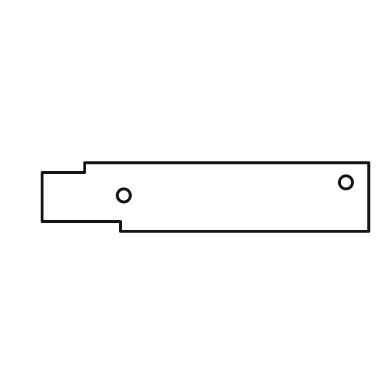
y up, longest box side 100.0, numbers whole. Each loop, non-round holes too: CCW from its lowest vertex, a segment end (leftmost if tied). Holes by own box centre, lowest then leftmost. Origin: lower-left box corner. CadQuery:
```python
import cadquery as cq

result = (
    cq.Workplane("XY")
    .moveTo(24.0, 0.0)
    .lineTo(100.0, 0.0)
    .lineTo(100.0, 21.0)
    .lineTo(13.0, 21.0)
    .lineTo(13.0, 18.0)
    .lineTo(0.0, 18.0)
    .lineTo(0.0, 3.0)
    .lineTo(24.0, 3.0)
    .close()
    .moveTo(25.0, 11.0)
    .circle(2.0)
    .moveTo(93.0, 15.0)
    .circle(2.0)
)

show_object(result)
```